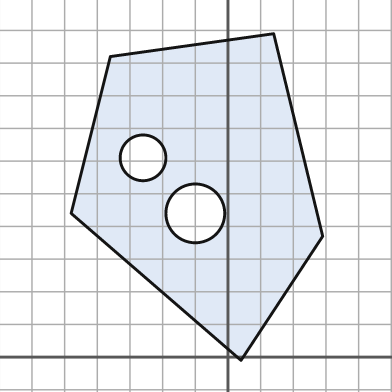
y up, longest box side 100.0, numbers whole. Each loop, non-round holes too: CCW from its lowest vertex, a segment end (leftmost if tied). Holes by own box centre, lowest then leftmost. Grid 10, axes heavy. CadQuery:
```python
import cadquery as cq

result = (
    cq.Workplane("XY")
    .moveTo(4.0, -1.0)
    .lineTo(29.0, 37.0)
    .lineTo(14.0, 99.0)
    .lineTo(-36.0, 92.0)
    .lineTo(-48.0, 44.0)
    .close()
    .moveTo(-10.0, 44.0)
    .circle(9.0)
    .moveTo(-26.0, 61.0)
    .circle(7.0)
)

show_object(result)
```